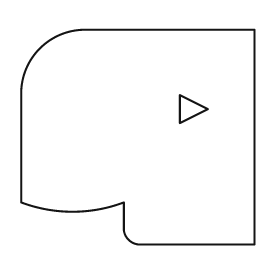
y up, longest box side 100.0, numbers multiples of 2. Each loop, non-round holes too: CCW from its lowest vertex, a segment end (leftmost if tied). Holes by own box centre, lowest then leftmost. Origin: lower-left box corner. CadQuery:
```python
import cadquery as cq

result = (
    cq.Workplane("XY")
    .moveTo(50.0, 0.0)
    .lineTo(100.0, 0.0)
    .lineTo(100.0, 92.0)
    .lineTo(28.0, 92.0)
    .threePointArc((8.0, 84.0), (0.0, 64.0))
    .lineTo(0.0, 18.0)
    .threePointArc((22.0, 14.0), (44.0, 18.0))
    .lineTo(44.0, 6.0)
    .threePointArc((46.0, 2.0), (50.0, 0.0))
    .close()
    .moveTo(68.0, 52.0)
    .lineTo(80.0, 58.0)
    .lineTo(68.0, 64.0)
    .close()
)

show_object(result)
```